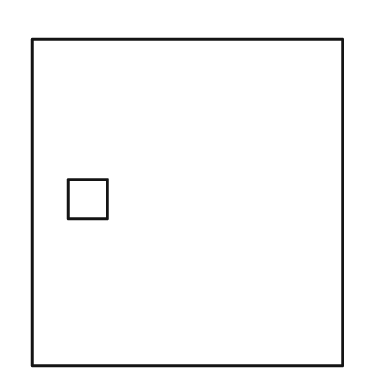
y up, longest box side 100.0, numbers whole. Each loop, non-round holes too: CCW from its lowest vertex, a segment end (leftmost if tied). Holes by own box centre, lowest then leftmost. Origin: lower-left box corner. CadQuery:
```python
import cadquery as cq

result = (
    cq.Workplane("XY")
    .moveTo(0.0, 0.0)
    .lineTo(95.0, 0.0)
    .lineTo(95.0, 100.0)
    .lineTo(0.0, 100.0)
    .close()
    .moveTo(11.0, 45.0)
    .lineTo(23.0, 45.0)
    .lineTo(23.0, 57.0)
    .lineTo(11.0, 57.0)
    .close()
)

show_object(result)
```